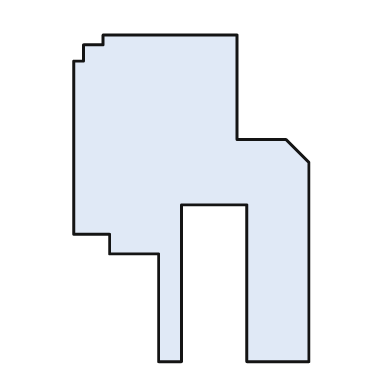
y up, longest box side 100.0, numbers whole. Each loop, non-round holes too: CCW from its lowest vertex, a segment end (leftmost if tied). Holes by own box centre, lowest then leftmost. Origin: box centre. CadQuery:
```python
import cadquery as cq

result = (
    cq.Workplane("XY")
    .moveTo(-10.0, -50.0)
    .lineTo(-3.0, -50.0)
    .lineTo(-3.0, -2.0)
    .lineTo(17.0, -2.0)
    .lineTo(17.0, -50.0)
    .lineTo(36.0, -50.0)
    .lineTo(36.0, 11.0)
    .lineTo(29.0, 18.0)
    .lineTo(14.0, 18.0)
    .lineTo(14.0, 50.0)
    .lineTo(-27.0, 50.0)
    .lineTo(-27.0, 47.0)
    .lineTo(-33.0, 47.0)
    .lineTo(-33.0, 42.0)
    .lineTo(-36.0, 42.0)
    .lineTo(-36.0, -11.0)
    .lineTo(-25.0, -11.0)
    .lineTo(-25.0, -17.0)
    .lineTo(-10.0, -17.0)
    .close()
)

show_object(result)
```